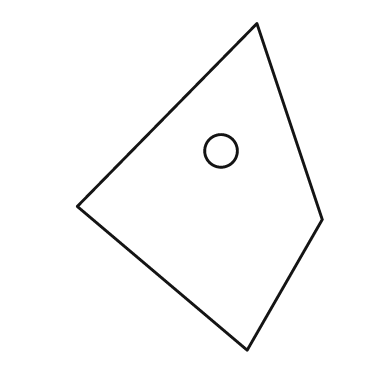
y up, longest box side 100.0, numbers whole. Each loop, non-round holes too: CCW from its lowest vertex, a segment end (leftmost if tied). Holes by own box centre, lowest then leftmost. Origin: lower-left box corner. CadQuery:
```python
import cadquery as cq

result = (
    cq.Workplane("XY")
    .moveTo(52.0, 0.0)
    .lineTo(75.0, 40.0)
    .lineTo(55.0, 100.0)
    .lineTo(0.0, 44.0)
    .close()
    .moveTo(44.0, 61.0)
    .circle(5.0)
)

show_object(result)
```